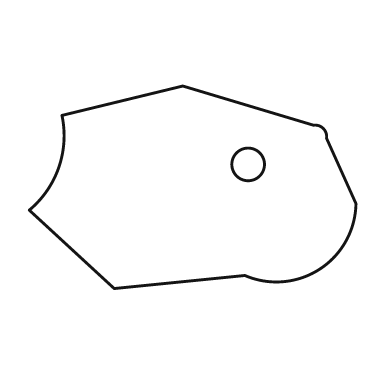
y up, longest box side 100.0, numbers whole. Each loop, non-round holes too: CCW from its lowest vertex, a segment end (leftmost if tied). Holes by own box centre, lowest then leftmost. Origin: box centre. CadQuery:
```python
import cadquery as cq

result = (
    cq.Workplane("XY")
    .moveTo(-24.0, -31.0)
    .lineTo(16.0, -27.0)
    .threePointArc((39.0, -25.0), (50.0, -5.0))
    .lineTo(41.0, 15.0)
    .threePointArc((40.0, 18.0), (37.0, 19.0))
    .lineTo(-3.0, 31.0)
    .lineTo(-40.0, 22.0)
    .threePointArc((-41.0, 6.0), (-50.0, -7.0))
    .close()
    .moveTo(17.0, 7.0)
    .circle(5.0)
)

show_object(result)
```